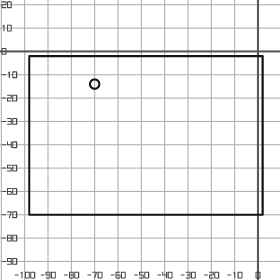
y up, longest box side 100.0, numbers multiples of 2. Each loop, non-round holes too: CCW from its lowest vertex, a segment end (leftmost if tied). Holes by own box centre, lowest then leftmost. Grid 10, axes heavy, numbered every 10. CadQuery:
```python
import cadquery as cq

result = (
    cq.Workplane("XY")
    .moveTo(-98.0, -70.0)
    .lineTo(2.0, -70.0)
    .lineTo(2.0, -2.0)
    .lineTo(-98.0, -2.0)
    .close()
    .moveTo(-70.0, -14.0)
    .circle(2.0)
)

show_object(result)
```